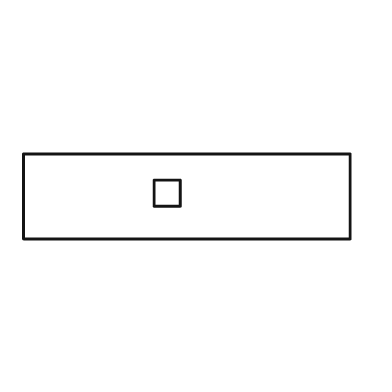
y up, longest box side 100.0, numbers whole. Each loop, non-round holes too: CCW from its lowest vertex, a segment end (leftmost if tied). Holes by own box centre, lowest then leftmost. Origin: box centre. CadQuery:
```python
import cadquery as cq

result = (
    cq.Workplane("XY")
    .moveTo(-50.0, -13.0)
    .lineTo(50.0, -13.0)
    .lineTo(50.0, 13.0)
    .lineTo(-50.0, 13.0)
    .close()
    .moveTo(-10.0, -3.0)
    .lineTo(-2.0, -3.0)
    .lineTo(-2.0, 5.0)
    .lineTo(-10.0, 5.0)
    .close()
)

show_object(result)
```